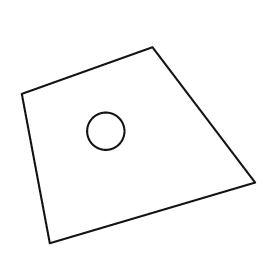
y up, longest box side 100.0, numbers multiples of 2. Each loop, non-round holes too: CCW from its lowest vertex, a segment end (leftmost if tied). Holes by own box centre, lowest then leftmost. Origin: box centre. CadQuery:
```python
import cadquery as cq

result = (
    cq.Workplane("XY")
    .moveTo(-38.0, -42.0)
    .lineTo(50.0, -16.0)
    .lineTo(6.0, 42.0)
    .lineTo(-50.0, 22.0)
    .close()
    .moveTo(-14.0, 6.0)
    .circle(8.0)
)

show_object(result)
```